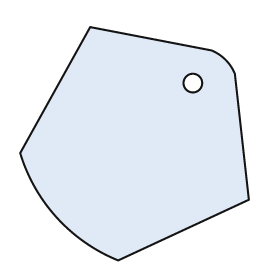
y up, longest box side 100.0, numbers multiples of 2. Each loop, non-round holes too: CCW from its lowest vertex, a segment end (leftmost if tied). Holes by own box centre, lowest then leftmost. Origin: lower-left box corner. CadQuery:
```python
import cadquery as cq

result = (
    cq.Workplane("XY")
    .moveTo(42.0, 0.0)
    .lineTo(98.0, 26.0)
    .lineTo(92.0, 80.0)
    .threePointArc((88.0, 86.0), (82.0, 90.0))
    .lineTo(30.0, 100.0)
    .lineTo(0.0, 46.0)
    .threePointArc((16.0, 18.0), (42.0, 0.0))
    .close()
    .moveTo(74.0, 76.0)
    .circle(4.0)
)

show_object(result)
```